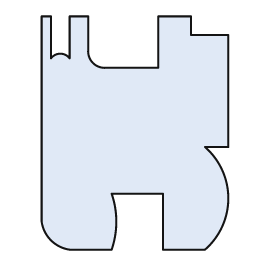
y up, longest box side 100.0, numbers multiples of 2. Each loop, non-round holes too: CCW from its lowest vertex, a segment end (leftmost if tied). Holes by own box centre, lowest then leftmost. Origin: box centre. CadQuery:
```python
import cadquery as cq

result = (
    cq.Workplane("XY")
    .moveTo(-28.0, -50.0)
    .lineTo(-10.0, -50.0)
    .threePointArc((-8.0, -38.0), (-10.0, -26.0))
    .lineTo(12.0, -26.0)
    .lineTo(12.0, -50.0)
    .lineTo(30.0, -50.0)
    .threePointArc((40.0, -28.0), (30.0, -6.0))
    .lineTo(40.0, -6.0)
    .lineTo(40.0, 42.0)
    .lineTo(24.0, 42.0)
    .lineTo(24.0, 50.0)
    .lineTo(10.0, 50.0)
    .lineTo(10.0, 28.0)
    .lineTo(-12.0, 28.0)
    .threePointArc((-18.0, 30.0), (-20.0, 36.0))
    .lineTo(-20.0, 50.0)
    .lineTo(-28.0, 50.0)
    .lineTo(-28.0, 32.0)
    .threePointArc((-32.0, 34.0), (-36.0, 32.0))
    .lineTo(-36.0, 50.0)
    .lineTo(-40.0, 50.0)
    .lineTo(-40.0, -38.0)
    .threePointArc((-36.0, -46.0), (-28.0, -50.0))
    .close()
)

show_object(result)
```